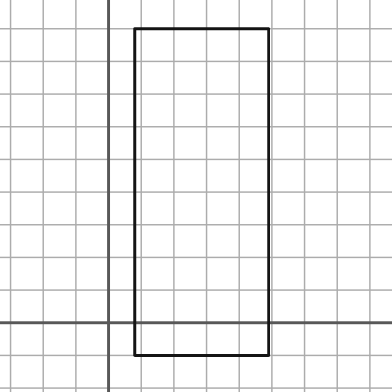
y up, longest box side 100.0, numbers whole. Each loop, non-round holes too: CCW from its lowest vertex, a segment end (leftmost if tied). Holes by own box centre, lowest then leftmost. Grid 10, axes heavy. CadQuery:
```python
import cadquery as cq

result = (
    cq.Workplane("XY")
    .moveTo(8.0, -10.0)
    .lineTo(49.0, -10.0)
    .lineTo(49.0, 90.0)
    .lineTo(8.0, 90.0)
    .close()
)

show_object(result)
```